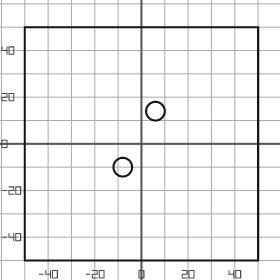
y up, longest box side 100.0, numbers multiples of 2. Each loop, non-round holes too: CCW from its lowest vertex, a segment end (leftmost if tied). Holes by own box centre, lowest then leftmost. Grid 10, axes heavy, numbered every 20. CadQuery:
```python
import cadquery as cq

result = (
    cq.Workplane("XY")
    .moveTo(-50.0, -50.0)
    .lineTo(50.0, -50.0)
    .lineTo(50.0, 50.0)
    .lineTo(-50.0, 50.0)
    .close()
    .moveTo(-8.0, -10.0)
    .circle(4.0)
    .moveTo(6.0, 14.0)
    .circle(4.0)
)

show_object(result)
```